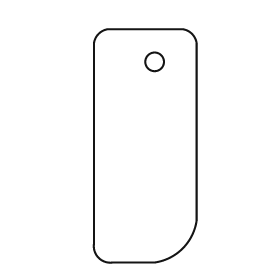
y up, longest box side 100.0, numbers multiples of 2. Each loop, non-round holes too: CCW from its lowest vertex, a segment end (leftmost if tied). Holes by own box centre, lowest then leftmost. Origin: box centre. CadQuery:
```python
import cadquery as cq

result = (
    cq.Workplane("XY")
    .moveTo(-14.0, -50.0)
    .lineTo(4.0, -50.0)
    .threePointArc((16.0, -44.0), (22.0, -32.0))
    .lineTo(22.0, 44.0)
    .threePointArc((20.0, 48.0), (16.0, 50.0))
    .lineTo(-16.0, 50.0)
    .threePointArc((-20.0, 48.0), (-22.0, 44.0))
    .lineTo(-22.0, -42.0)
    .threePointArc((-20.0, -48.0), (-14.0, -50.0))
    .close()
    .moveTo(4.0, 36.0)
    .circle(4.0)
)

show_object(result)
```